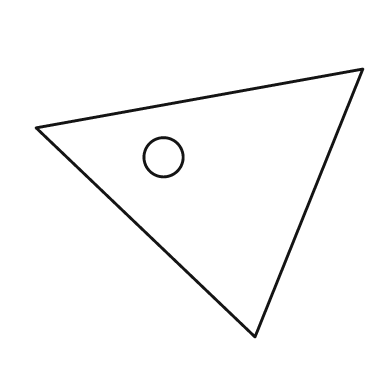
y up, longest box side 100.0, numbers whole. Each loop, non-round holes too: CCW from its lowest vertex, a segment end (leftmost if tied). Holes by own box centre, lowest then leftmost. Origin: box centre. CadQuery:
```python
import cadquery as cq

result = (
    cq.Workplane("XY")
    .moveTo(17.0, -41.0)
    .lineTo(50.0, 41.0)
    .lineTo(-50.0, 23.0)
    .close()
    .moveTo(-11.0, 14.0)
    .circle(6.0)
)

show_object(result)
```